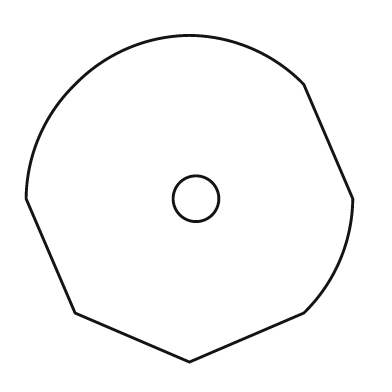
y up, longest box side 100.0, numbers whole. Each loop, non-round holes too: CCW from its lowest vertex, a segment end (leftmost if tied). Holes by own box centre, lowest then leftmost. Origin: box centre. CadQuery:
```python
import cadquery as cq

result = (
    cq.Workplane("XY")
    .moveTo(0.0, -50.0)
    .lineTo(35.0, -35.0)
    .threePointArc((46.0, -19.0), (50.0, 0.0))
    .lineTo(35.0, 35.0)
    .threePointArc((19.0, 46.0), (0.0, 50.0))
    .threePointArc((-19.0, 46.0), (-35.0, 35.0))
    .threePointArc((-46.0, 19.0), (-50.0, 0.0))
    .lineTo(-35.0, -35.0)
    .close()
    .moveTo(2.0, 0.0)
    .circle(7.0)
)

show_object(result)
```